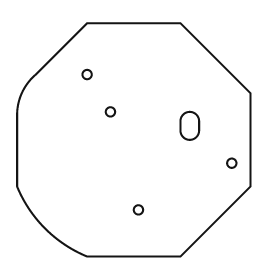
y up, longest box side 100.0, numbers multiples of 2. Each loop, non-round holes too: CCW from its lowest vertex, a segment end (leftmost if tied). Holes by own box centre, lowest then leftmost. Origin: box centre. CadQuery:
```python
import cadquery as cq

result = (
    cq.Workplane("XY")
    .moveTo(-20.0, -50.0)
    .lineTo(20.0, -50.0)
    .lineTo(50.0, -20.0)
    .lineTo(50.0, 20.0)
    .lineTo(20.0, 50.0)
    .lineTo(-20.0, 50.0)
    .lineTo(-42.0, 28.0)
    .threePointArc((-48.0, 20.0), (-50.0, 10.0))
    .lineTo(-50.0, -20.0)
    .threePointArc((-38.0, -38.0), (-20.0, -50.0))
    .close()
    .moveTo(2.0, -30.0)
    .circle(2.0)
    .moveTo(42.0, -10.0)
    .circle(2.0)
    .moveTo(20.0, 4.0)
    .threePointArc((24.0, 0.0), (28.0, 4.0))
    .lineTo(28.0, 8.0)
    .threePointArc((24.0, 12.0), (20.0, 8.0))
    .close()
    .moveTo(-10.0, 12.0)
    .circle(2.0)
    .moveTo(-20.0, 28.0)
    .circle(2.0)
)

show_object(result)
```